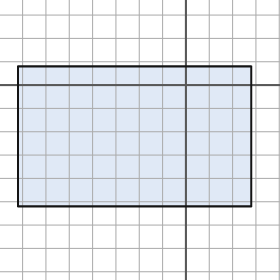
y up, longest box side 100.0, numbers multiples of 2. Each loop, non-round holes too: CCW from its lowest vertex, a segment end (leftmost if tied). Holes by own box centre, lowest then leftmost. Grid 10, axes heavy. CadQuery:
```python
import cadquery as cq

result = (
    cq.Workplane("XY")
    .moveTo(-72.0, -52.0)
    .lineTo(28.0, -52.0)
    .lineTo(28.0, 8.0)
    .lineTo(-72.0, 8.0)
    .close()
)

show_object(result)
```